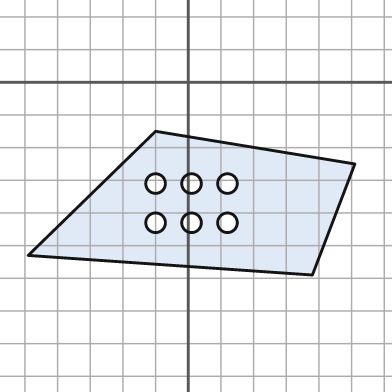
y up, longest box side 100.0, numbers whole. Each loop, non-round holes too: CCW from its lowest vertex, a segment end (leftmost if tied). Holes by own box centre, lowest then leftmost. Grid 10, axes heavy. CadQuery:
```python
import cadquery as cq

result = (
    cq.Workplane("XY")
    .moveTo(38.0, -59.0)
    .lineTo(51.0, -25.0)
    .lineTo(-10.0, -15.0)
    .lineTo(-49.0, -53.0)
    .close()
    .moveTo(-10.0, -43.0)
    .circle(3.0)
    .moveTo(1.0, -43.0)
    .circle(3.0)
    .moveTo(12.0, -43.0)
    .circle(3.0)
    .moveTo(-10.0, -31.0)
    .circle(3.0)
    .moveTo(1.0, -31.0)
    .circle(3.0)
    .moveTo(12.0, -31.0)
    .circle(3.0)
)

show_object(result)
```